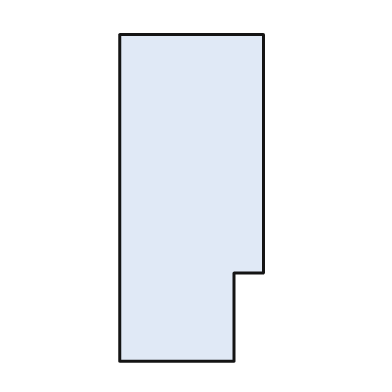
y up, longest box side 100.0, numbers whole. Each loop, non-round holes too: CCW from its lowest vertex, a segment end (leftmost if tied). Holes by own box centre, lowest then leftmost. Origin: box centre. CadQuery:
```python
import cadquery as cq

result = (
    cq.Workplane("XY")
    .moveTo(-22.0, -50.0)
    .lineTo(13.0, -50.0)
    .lineTo(13.0, -23.0)
    .lineTo(22.0, -23.0)
    .lineTo(22.0, 50.0)
    .lineTo(-22.0, 50.0)
    .close()
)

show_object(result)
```